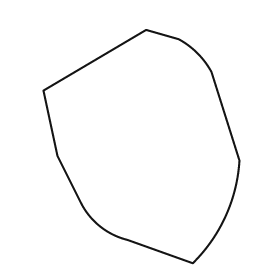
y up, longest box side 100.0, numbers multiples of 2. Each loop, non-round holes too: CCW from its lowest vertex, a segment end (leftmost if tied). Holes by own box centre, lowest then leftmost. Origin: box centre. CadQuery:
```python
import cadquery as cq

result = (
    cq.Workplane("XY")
    .moveTo(22.0, -50.0)
    .threePointArc((36.0, -30.0), (42.0, -6.0))
    .lineTo(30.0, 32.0)
    .threePointArc((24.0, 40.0), (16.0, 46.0))
    .lineTo(2.0, 50.0)
    .lineTo(-42.0, 24.0)
    .lineTo(-36.0, -4.0)
    .lineTo(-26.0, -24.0)
    .threePointArc((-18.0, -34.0), (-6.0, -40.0))
    .close()
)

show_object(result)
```